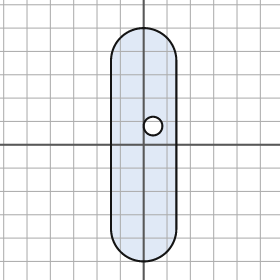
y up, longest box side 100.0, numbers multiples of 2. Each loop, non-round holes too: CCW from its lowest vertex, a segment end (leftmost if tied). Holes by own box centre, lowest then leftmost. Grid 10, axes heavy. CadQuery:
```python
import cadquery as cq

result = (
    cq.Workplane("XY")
    .moveTo(-14.0, -36.0)
    .threePointArc((0.0, -50.0), (14.0, -36.0))
    .lineTo(14.0, 36.0)
    .threePointArc((0.0, 50.0), (-14.0, 36.0))
    .close()
    .moveTo(4.0, 8.0)
    .circle(4.0)
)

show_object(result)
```